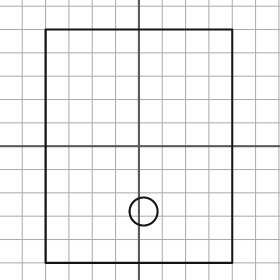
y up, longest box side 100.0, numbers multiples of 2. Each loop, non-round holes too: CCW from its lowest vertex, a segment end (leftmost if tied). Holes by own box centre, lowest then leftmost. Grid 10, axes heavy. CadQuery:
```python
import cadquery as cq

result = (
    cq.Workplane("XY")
    .moveTo(-40.0, -50.0)
    .lineTo(40.0, -50.0)
    .lineTo(40.0, 50.0)
    .lineTo(-40.0, 50.0)
    .close()
    .moveTo(2.0, -28.0)
    .circle(6.0)
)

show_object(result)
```